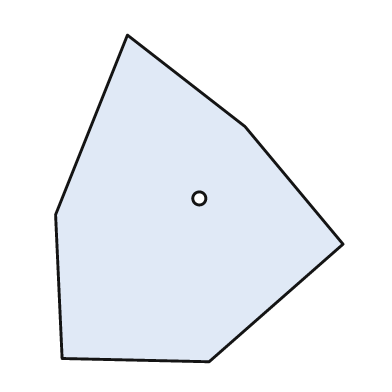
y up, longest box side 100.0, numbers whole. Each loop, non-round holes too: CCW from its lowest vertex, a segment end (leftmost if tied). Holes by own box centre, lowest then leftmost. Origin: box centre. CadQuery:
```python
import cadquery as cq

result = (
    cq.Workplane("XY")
    .moveTo(3.0, -50.0)
    .lineTo(44.0, -14.0)
    .lineTo(14.0, 22.0)
    .lineTo(-22.0, 50.0)
    .lineTo(-44.0, -5.0)
    .lineTo(-42.0, -49.0)
    .close()
    .moveTo(0.0, 0.0)
    .circle(2.0)
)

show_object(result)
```